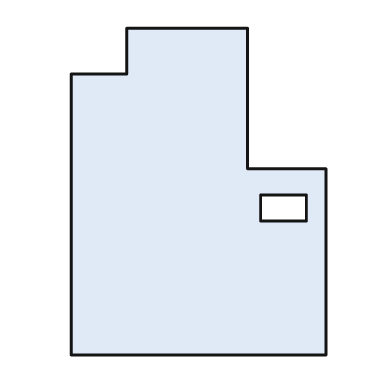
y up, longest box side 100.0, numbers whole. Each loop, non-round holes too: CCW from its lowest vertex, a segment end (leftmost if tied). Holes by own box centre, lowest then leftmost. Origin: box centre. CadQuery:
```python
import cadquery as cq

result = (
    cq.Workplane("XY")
    .moveTo(-39.0, -50.0)
    .lineTo(39.0, -50.0)
    .lineTo(39.0, 7.0)
    .lineTo(15.0, 7.0)
    .lineTo(15.0, 50.0)
    .lineTo(-22.0, 50.0)
    .lineTo(-22.0, 36.0)
    .lineTo(-39.0, 36.0)
    .close()
    .moveTo(19.0, -9.0)
    .lineTo(33.0, -9.0)
    .lineTo(33.0, -1.0)
    .lineTo(19.0, -1.0)
    .close()
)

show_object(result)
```